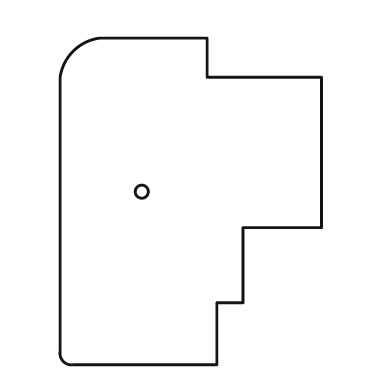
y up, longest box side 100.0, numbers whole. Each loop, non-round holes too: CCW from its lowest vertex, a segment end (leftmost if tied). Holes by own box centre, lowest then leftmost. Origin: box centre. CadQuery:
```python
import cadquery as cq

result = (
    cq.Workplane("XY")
    .moveTo(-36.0, -50.0)
    .lineTo(8.0, -50.0)
    .lineTo(8.0, -31.0)
    .lineTo(16.0, -31.0)
    .lineTo(16.0, -8.0)
    .lineTo(40.0, -8.0)
    .lineTo(40.0, 38.0)
    .lineTo(5.0, 38.0)
    .lineTo(5.0, 50.0)
    .lineTo(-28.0, 50.0)
    .threePointArc((-36.0, 46.0), (-40.0, 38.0))
    .lineTo(-40.0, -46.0)
    .threePointArc((-39.0, -49.0), (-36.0, -50.0))
    .close()
    .moveTo(-15.0, 3.0)
    .circle(2.0)
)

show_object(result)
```